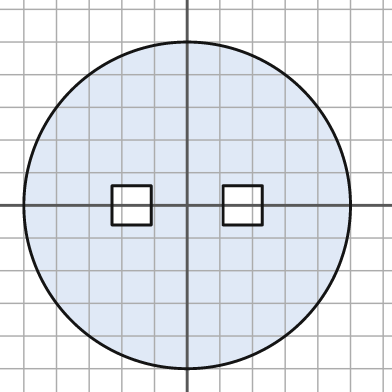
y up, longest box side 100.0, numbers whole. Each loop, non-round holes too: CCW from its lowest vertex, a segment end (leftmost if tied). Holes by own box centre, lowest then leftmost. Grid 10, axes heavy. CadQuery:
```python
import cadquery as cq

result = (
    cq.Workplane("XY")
    .moveTo(0.0, 0.0)
    .circle(50.0)
    .moveTo(-23.0, -6.0)
    .lineTo(-11.0, -6.0)
    .lineTo(-11.0, 6.0)
    .lineTo(-23.0, 6.0)
    .close()
    .moveTo(11.0, -6.0)
    .lineTo(23.0, -6.0)
    .lineTo(23.0, 6.0)
    .lineTo(11.0, 6.0)
    .close()
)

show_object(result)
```